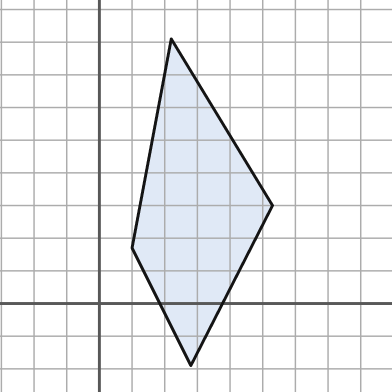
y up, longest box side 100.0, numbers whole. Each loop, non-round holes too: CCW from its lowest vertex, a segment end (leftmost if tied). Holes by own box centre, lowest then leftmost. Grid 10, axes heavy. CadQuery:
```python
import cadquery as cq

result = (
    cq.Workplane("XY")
    .moveTo(28.0, -19.0)
    .lineTo(53.0, 30.0)
    .lineTo(22.0, 81.0)
    .lineTo(10.0, 17.0)
    .close()
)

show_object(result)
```